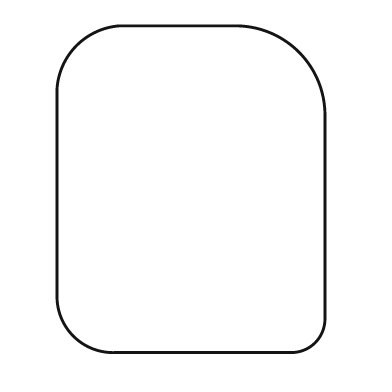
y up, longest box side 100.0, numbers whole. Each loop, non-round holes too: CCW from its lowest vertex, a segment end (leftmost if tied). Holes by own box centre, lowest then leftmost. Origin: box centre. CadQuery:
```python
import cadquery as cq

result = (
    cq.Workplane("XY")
    .moveTo(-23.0, -50.0)
    .lineTo(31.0, -50.0)
    .threePointArc((38.0, -47.0), (41.0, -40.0))
    .lineTo(41.0, 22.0)
    .threePointArc((33.0, 42.0), (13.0, 50.0))
    .lineTo(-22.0, 50.0)
    .threePointArc((-35.0, 44.0), (-41.0, 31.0))
    .lineTo(-41.0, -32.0)
    .threePointArc((-36.0, -45.0), (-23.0, -50.0))
    .close()
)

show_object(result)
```